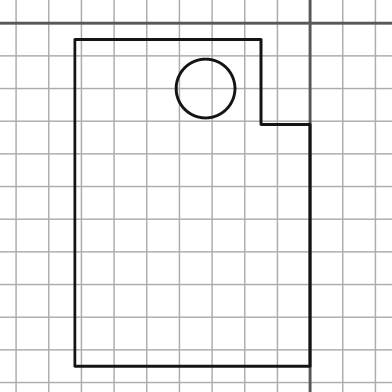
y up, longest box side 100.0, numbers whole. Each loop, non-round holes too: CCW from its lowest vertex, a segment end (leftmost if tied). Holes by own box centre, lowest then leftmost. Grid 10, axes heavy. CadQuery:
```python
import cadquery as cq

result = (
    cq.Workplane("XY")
    .moveTo(-72.0, -105.0)
    .lineTo(0.0, -105.0)
    .lineTo(0.0, -31.0)
    .lineTo(-15.0, -31.0)
    .lineTo(-15.0, -5.0)
    .lineTo(-72.0, -5.0)
    .close()
    .moveTo(-32.0, -20.0)
    .circle(9.0)
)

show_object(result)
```